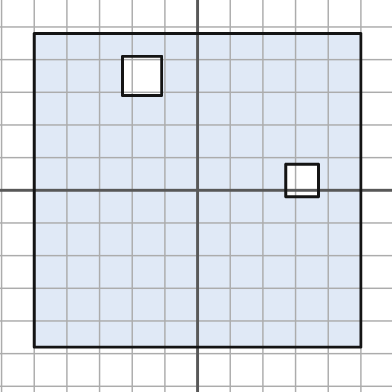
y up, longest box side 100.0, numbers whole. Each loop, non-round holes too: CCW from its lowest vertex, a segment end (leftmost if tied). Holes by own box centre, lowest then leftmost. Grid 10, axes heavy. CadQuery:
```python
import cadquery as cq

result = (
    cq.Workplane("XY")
    .moveTo(-50.0, -48.0)
    .lineTo(50.0, -48.0)
    .lineTo(50.0, 48.0)
    .lineTo(-50.0, 48.0)
    .close()
    .moveTo(27.0, -2.0)
    .lineTo(37.0, -2.0)
    .lineTo(37.0, 8.0)
    .lineTo(27.0, 8.0)
    .close()
    .moveTo(-23.0, 29.0)
    .lineTo(-11.0, 29.0)
    .lineTo(-11.0, 41.0)
    .lineTo(-23.0, 41.0)
    .close()
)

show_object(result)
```